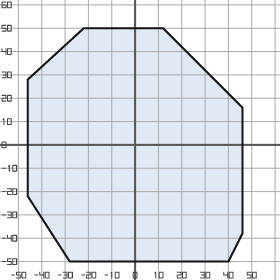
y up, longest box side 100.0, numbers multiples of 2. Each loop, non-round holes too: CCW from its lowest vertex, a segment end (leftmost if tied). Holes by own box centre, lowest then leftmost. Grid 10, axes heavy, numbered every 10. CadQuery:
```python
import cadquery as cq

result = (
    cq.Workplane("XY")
    .moveTo(-28.0, -50.0)
    .lineTo(40.0, -50.0)
    .lineTo(46.0, -38.0)
    .lineTo(46.0, 16.0)
    .lineTo(12.0, 50.0)
    .lineTo(-22.0, 50.0)
    .lineTo(-46.0, 28.0)
    .lineTo(-46.0, -22.0)
    .close()
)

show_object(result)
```